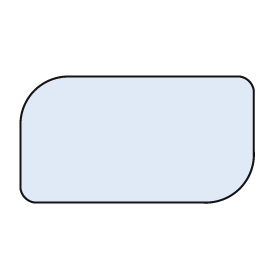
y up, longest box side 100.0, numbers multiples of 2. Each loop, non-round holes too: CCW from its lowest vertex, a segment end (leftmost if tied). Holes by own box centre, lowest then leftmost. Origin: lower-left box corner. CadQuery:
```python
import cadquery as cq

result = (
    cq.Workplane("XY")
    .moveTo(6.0, 0.0)
    .lineTo(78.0, 0.0)
    .threePointArc((94.0, 6.0), (100.0, 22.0))
    .lineTo(100.0, 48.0)
    .threePointArc((98.0, 52.0), (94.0, 54.0))
    .lineTo(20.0, 54.0)
    .threePointArc((6.0, 48.0), (0.0, 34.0))
    .lineTo(0.0, 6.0)
    .threePointArc((2.0, 2.0), (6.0, 0.0))
    .close()
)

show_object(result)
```